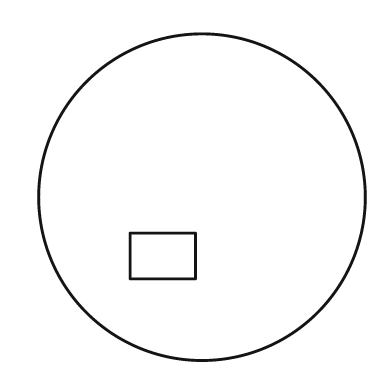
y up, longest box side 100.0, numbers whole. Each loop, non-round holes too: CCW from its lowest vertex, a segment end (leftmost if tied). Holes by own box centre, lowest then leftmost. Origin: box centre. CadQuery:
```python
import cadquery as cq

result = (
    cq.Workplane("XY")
    .moveTo(0.0, 0.0)
    .circle(50.0)
    .moveTo(-22.0, -25.0)
    .lineTo(-2.0, -25.0)
    .lineTo(-2.0, -11.0)
    .lineTo(-22.0, -11.0)
    .close()
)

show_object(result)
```